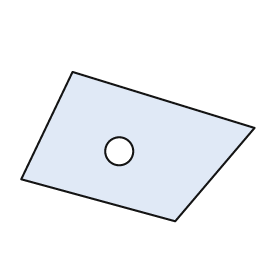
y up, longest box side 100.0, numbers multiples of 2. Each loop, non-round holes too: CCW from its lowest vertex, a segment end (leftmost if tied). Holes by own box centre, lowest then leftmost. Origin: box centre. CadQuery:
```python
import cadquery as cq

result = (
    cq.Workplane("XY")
    .moveTo(16.0, -32.0)
    .lineTo(50.0, 8.0)
    .lineTo(-28.0, 32.0)
    .lineTo(-50.0, -14.0)
    .close()
    .moveTo(-8.0, -2.0)
    .circle(6.0)
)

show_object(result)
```